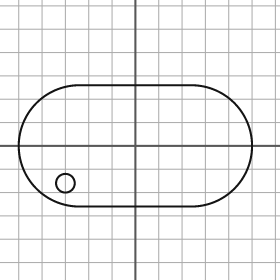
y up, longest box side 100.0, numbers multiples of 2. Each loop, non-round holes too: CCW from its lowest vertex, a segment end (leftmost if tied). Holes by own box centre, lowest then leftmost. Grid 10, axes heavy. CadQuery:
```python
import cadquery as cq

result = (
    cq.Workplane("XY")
    .moveTo(-24.0, -26.0)
    .lineTo(24.0, -26.0)
    .threePointArc((50.0, 0.0), (24.0, 26.0))
    .lineTo(-24.0, 26.0)
    .threePointArc((-50.0, 0.0), (-24.0, -26.0))
    .close()
    .moveTo(-30.0, -16.0)
    .circle(4.0)
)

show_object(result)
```